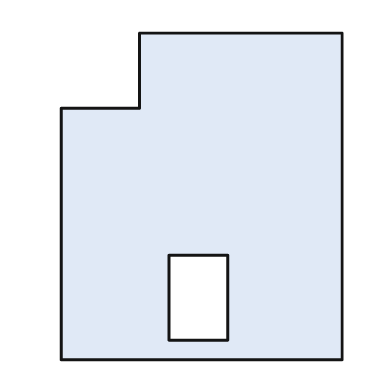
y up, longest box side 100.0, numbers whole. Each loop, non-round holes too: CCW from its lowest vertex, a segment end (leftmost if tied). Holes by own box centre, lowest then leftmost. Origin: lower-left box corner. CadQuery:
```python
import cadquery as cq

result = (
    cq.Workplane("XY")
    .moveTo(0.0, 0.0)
    .lineTo(86.0, 0.0)
    .lineTo(86.0, 100.0)
    .lineTo(24.0, 100.0)
    .lineTo(24.0, 77.0)
    .lineTo(0.0, 77.0)
    .close()
    .moveTo(33.0, 6.0)
    .lineTo(51.0, 6.0)
    .lineTo(51.0, 32.0)
    .lineTo(33.0, 32.0)
    .close()
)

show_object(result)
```